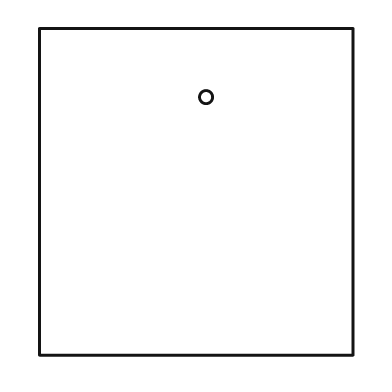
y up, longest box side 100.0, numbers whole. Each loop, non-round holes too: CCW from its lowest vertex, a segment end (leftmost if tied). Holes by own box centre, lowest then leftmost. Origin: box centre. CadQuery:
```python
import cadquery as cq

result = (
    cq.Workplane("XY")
    .moveTo(-48.0, -50.0)
    .lineTo(48.0, -50.0)
    .lineTo(48.0, 50.0)
    .lineTo(-48.0, 50.0)
    .close()
    .moveTo(3.0, 29.0)
    .circle(2.0)
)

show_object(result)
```